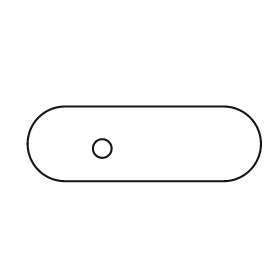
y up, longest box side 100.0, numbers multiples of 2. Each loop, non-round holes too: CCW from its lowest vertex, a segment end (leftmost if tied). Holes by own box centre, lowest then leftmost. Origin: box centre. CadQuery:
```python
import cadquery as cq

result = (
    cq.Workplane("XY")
    .moveTo(-34.0, -16.0)
    .lineTo(34.0, -16.0)
    .threePointArc((50.0, 0.0), (34.0, 16.0))
    .lineTo(-34.0, 16.0)
    .threePointArc((-50.0, 0.0), (-34.0, -16.0))
    .close()
    .moveTo(-18.0, -2.0)
    .circle(4.0)
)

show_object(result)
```